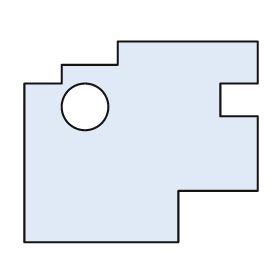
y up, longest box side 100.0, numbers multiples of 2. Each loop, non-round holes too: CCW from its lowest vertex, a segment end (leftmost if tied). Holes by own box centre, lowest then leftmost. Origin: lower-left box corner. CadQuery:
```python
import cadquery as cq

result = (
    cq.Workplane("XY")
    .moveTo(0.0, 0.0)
    .lineTo(66.0, 0.0)
    .lineTo(66.0, 22.0)
    .lineTo(100.0, 22.0)
    .lineTo(100.0, 54.0)
    .lineTo(84.0, 54.0)
    .lineTo(84.0, 68.0)
    .lineTo(100.0, 68.0)
    .lineTo(100.0, 86.0)
    .lineTo(40.0, 86.0)
    .lineTo(40.0, 76.0)
    .lineTo(16.0, 76.0)
    .lineTo(16.0, 68.0)
    .lineTo(0.0, 68.0)
    .close()
    .moveTo(26.0, 58.0)
    .circle(10.0)
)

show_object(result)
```